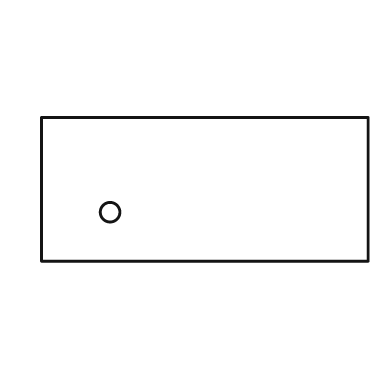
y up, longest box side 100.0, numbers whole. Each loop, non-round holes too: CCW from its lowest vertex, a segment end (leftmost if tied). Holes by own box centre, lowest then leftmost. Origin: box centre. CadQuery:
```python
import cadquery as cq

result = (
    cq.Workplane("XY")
    .moveTo(-50.0, -22.0)
    .lineTo(50.0, -22.0)
    .lineTo(50.0, 22.0)
    .lineTo(-50.0, 22.0)
    .close()
    .moveTo(-29.0, -7.0)
    .circle(3.0)
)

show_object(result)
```